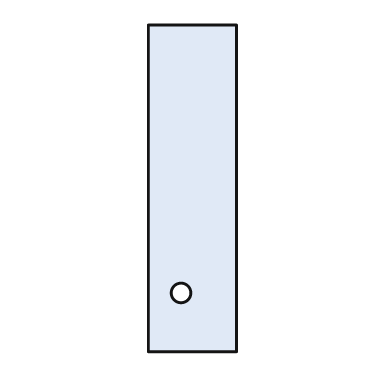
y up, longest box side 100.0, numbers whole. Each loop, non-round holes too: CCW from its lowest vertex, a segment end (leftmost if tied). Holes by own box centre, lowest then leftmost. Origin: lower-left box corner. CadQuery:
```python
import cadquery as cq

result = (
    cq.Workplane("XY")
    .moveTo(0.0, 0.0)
    .lineTo(27.0, 0.0)
    .lineTo(27.0, 100.0)
    .lineTo(0.0, 100.0)
    .close()
    .moveTo(10.0, 18.0)
    .circle(3.0)
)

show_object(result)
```